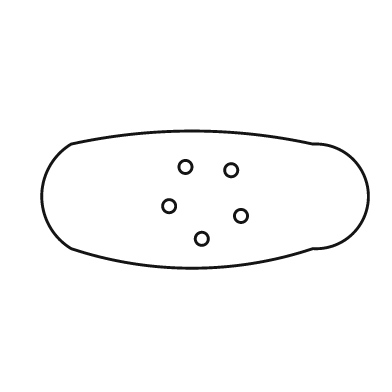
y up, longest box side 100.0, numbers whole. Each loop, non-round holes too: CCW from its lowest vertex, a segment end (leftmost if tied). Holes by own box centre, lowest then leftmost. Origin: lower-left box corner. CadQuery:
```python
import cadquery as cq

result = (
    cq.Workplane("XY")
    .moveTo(9.0, 6.0)
    .threePointArc((46.0, 0.0), (83.0, 6.0))
    .threePointArc((100.0, 22.0), (83.0, 38.0))
    .threePointArc((46.0, 42.0), (9.0, 38.0))
    .threePointArc((0.0, 22.0), (9.0, 6.0))
    .close()
    .moveTo(49.0, 9.0)
    .circle(2.0)
    .moveTo(61.0, 16.0)
    .circle(2.0)
    .moveTo(39.0, 19.0)
    .circle(2.0)
    .moveTo(58.0, 30.0)
    .circle(2.0)
    .moveTo(44.0, 31.0)
    .circle(2.0)
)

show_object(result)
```